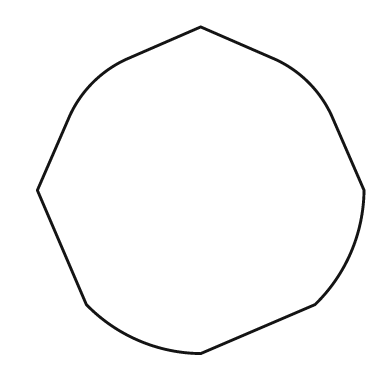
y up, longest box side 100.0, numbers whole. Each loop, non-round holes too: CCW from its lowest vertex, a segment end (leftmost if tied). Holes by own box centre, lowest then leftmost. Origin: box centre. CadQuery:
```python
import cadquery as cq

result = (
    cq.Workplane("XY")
    .moveTo(0.0, -50.0)
    .lineTo(35.0, -35.0)
    .threePointArc((46.0, -19.0), (50.0, 0.0))
    .lineTo(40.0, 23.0)
    .threePointArc((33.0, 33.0), (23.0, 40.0))
    .lineTo(0.0, 50.0)
    .lineTo(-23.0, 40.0)
    .threePointArc((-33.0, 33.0), (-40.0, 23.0))
    .lineTo(-50.0, 0.0)
    .lineTo(-35.0, -35.0)
    .threePointArc((-19.0, -46.0), (0.0, -50.0))
    .close()
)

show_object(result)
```